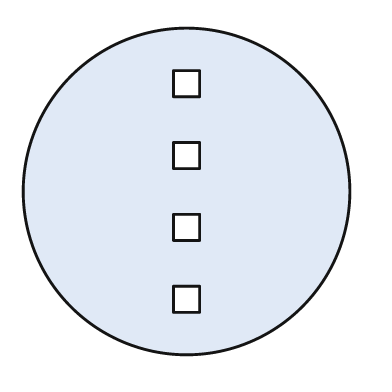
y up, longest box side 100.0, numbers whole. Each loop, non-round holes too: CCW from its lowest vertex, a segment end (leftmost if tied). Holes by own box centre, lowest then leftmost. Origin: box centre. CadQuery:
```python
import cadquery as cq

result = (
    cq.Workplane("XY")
    .moveTo(0.0, 0.0)
    .circle(50.0)
    .moveTo(-4.0, -37.0)
    .lineTo(4.0, -37.0)
    .lineTo(4.0, -29.0)
    .lineTo(-4.0, -29.0)
    .close()
    .moveTo(-4.0, -15.0)
    .lineTo(4.0, -15.0)
    .lineTo(4.0, -7.0)
    .lineTo(-4.0, -7.0)
    .close()
    .moveTo(-4.0, 7.0)
    .lineTo(4.0, 7.0)
    .lineTo(4.0, 15.0)
    .lineTo(-4.0, 15.0)
    .close()
    .moveTo(-4.0, 29.0)
    .lineTo(4.0, 29.0)
    .lineTo(4.0, 37.0)
    .lineTo(-4.0, 37.0)
    .close()
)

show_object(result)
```